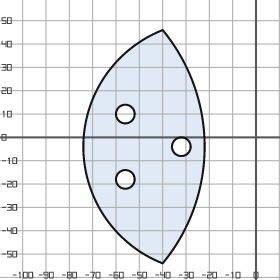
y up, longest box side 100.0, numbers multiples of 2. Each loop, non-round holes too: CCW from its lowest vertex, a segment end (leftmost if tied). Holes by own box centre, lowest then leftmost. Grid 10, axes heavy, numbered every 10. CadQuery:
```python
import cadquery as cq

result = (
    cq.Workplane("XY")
    .moveTo(-40.0, -54.0)
    .threePointArc((-22.0, -4.0), (-40.0, 46.0))
    .threePointArc((-74.0, -4.0), (-40.0, -54.0))
    .close()
    .moveTo(-56.0, -18.0)
    .circle(4.0)
    .moveTo(-32.0, -4.0)
    .circle(4.0)
    .moveTo(-56.0, 10.0)
    .circle(4.0)
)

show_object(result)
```